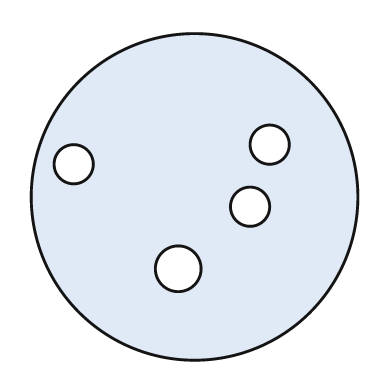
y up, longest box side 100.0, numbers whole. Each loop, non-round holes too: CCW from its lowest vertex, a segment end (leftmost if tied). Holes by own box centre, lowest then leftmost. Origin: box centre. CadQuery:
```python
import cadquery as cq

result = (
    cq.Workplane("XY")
    .moveTo(0.0, 0.0)
    .circle(50.0)
    .moveTo(-5.0, -22.0)
    .circle(7.0)
    .moveTo(17.0, -3.0)
    .circle(6.0)
    .moveTo(-37.0, 10.0)
    .circle(6.0)
    .moveTo(23.0, 16.0)
    .circle(6.0)
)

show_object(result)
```